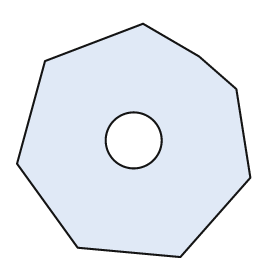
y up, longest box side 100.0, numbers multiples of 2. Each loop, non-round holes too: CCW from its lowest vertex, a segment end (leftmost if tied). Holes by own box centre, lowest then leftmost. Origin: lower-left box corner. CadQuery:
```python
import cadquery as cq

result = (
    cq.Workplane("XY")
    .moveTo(70.0, 0.0)
    .lineTo(100.0, 34.0)
    .lineTo(94.0, 72.0)
    .lineTo(78.0, 86.0)
    .lineTo(54.0, 100.0)
    .lineTo(12.0, 84.0)
    .lineTo(0.0, 40.0)
    .lineTo(26.0, 4.0)
    .close()
    .moveTo(50.0, 50.0)
    .circle(12.0)
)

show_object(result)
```